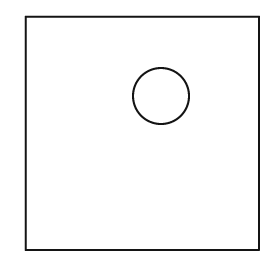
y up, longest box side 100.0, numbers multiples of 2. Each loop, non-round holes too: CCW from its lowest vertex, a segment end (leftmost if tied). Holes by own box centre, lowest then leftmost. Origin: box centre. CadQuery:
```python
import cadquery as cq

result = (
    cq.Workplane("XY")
    .moveTo(-50.0, -50.0)
    .lineTo(50.0, -50.0)
    .lineTo(50.0, 50.0)
    .lineTo(-50.0, 50.0)
    .close()
    .moveTo(8.0, 16.0)
    .circle(12.0)
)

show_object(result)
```